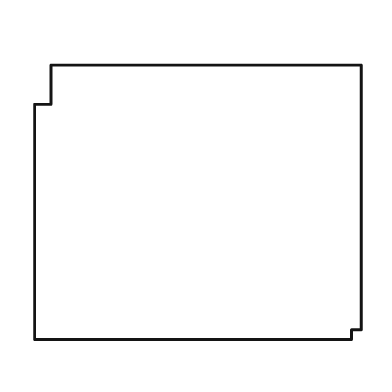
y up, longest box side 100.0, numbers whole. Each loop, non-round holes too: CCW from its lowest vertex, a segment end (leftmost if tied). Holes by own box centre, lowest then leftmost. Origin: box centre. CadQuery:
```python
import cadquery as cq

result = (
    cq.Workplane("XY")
    .moveTo(-50.0, -42.0)
    .lineTo(47.0, -42.0)
    .lineTo(47.0, -39.0)
    .lineTo(50.0, -39.0)
    .lineTo(50.0, 42.0)
    .lineTo(-45.0, 42.0)
    .lineTo(-45.0, 30.0)
    .lineTo(-50.0, 30.0)
    .close()
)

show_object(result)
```